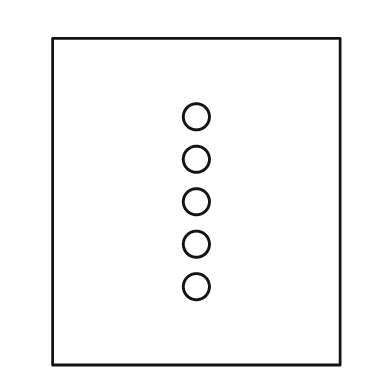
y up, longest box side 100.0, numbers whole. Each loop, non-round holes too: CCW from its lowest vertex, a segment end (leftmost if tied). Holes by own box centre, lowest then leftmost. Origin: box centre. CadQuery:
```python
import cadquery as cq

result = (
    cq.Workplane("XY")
    .moveTo(-44.0, -50.0)
    .lineTo(44.0, -50.0)
    .lineTo(44.0, 50.0)
    .lineTo(-44.0, 50.0)
    .close()
    .moveTo(0.0, -26.0)
    .circle(4.0)
    .moveTo(0.0, -13.0)
    .circle(4.0)
    .moveTo(0.0, 0.0)
    .circle(4.0)
    .moveTo(0.0, 13.0)
    .circle(4.0)
    .moveTo(0.0, 26.0)
    .circle(4.0)
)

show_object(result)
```